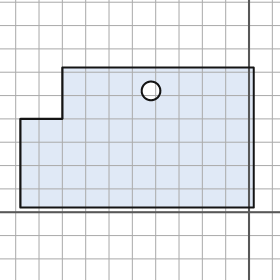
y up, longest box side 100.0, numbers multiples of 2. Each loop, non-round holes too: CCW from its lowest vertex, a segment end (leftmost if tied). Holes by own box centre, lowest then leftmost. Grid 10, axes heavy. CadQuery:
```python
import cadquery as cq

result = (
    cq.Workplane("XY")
    .moveTo(-98.0, 2.0)
    .lineTo(2.0, 2.0)
    .lineTo(2.0, 62.0)
    .lineTo(-80.0, 62.0)
    .lineTo(-80.0, 40.0)
    .lineTo(-98.0, 40.0)
    .close()
    .moveTo(-42.0, 52.0)
    .circle(4.0)
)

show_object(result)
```